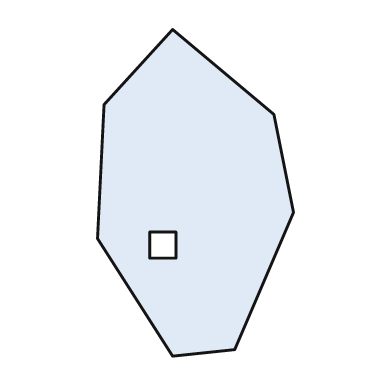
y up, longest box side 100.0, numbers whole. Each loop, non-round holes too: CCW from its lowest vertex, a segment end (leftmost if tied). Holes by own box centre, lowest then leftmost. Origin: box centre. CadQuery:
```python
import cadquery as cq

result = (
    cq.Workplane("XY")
    .moveTo(-7.0, -50.0)
    .lineTo(12.0, -48.0)
    .lineTo(30.0, -6.0)
    .lineTo(24.0, 24.0)
    .lineTo(-7.0, 50.0)
    .lineTo(-28.0, 27.0)
    .lineTo(-30.0, -14.0)
    .close()
    .moveTo(-14.0, -20.0)
    .lineTo(-6.0, -20.0)
    .lineTo(-6.0, -12.0)
    .lineTo(-14.0, -12.0)
    .close()
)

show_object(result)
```